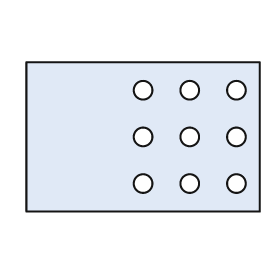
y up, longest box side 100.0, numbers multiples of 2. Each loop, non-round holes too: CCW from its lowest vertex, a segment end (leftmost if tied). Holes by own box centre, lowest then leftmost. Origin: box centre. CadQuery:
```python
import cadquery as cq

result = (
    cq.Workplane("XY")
    .moveTo(-50.0, -32.0)
    .lineTo(50.0, -32.0)
    .lineTo(50.0, 32.0)
    .lineTo(-50.0, 32.0)
    .close()
    .moveTo(0.0, -20.0)
    .circle(4.0)
    .moveTo(20.0, -20.0)
    .circle(4.0)
    .moveTo(40.0, -20.0)
    .circle(4.0)
    .moveTo(0.0, 0.0)
    .circle(4.0)
    .moveTo(20.0, 0.0)
    .circle(4.0)
    .moveTo(40.0, 0.0)
    .circle(4.0)
    .moveTo(0.0, 20.0)
    .circle(4.0)
    .moveTo(20.0, 20.0)
    .circle(4.0)
    .moveTo(40.0, 20.0)
    .circle(4.0)
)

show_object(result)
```